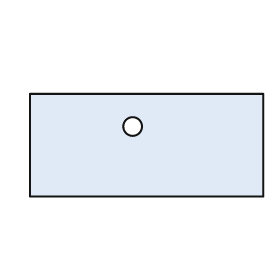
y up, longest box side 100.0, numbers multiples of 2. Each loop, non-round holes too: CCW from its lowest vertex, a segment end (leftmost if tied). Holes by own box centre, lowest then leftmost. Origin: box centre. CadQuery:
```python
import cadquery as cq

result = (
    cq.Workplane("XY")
    .moveTo(-50.0, -22.0)
    .lineTo(50.0, -22.0)
    .lineTo(50.0, 22.0)
    .lineTo(-50.0, 22.0)
    .close()
    .moveTo(-6.0, 8.0)
    .circle(4.0)
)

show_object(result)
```